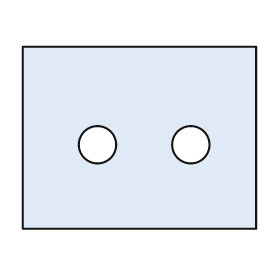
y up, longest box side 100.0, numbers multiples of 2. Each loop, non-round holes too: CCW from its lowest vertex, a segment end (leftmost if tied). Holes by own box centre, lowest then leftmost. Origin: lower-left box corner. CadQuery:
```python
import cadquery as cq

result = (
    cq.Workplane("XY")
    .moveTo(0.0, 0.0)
    .lineTo(100.0, 0.0)
    .lineTo(100.0, 78.0)
    .lineTo(0.0, 78.0)
    .close()
    .moveTo(32.0, 36.0)
    .circle(8.0)
    .moveTo(72.0, 36.0)
    .circle(8.0)
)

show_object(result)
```